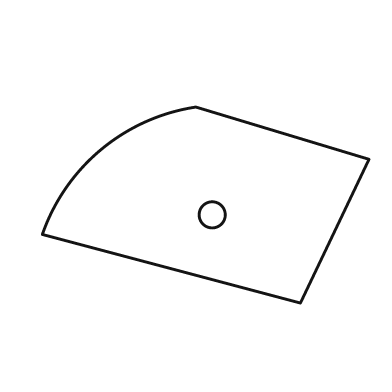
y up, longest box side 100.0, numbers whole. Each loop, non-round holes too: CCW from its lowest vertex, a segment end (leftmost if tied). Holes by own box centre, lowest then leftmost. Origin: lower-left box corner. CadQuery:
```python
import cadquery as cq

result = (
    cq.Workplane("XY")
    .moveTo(79.0, 0.0)
    .lineTo(100.0, 44.0)
    .lineTo(47.0, 60.0)
    .threePointArc((18.0, 47.0), (0.0, 21.0))
    .close()
    .moveTo(52.0, 27.0)
    .circle(4.0)
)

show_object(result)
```